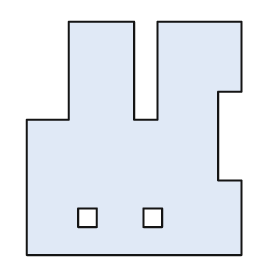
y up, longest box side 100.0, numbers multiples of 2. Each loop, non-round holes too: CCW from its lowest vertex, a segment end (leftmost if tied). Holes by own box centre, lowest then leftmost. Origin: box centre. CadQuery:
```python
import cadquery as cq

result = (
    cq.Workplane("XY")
    .moveTo(-46.0, -50.0)
    .lineTo(46.0, -50.0)
    .lineTo(46.0, -18.0)
    .lineTo(36.0, -18.0)
    .lineTo(36.0, 20.0)
    .lineTo(46.0, 20.0)
    .lineTo(46.0, 50.0)
    .lineTo(10.0, 50.0)
    .lineTo(10.0, 8.0)
    .lineTo(0.0, 8.0)
    .lineTo(0.0, 50.0)
    .lineTo(-28.0, 50.0)
    .lineTo(-28.0, 8.0)
    .lineTo(-46.0, 8.0)
    .close()
    .moveTo(-24.0, -38.0)
    .lineTo(-16.0, -38.0)
    .lineTo(-16.0, -30.0)
    .lineTo(-24.0, -30.0)
    .close()
    .moveTo(4.0, -38.0)
    .lineTo(12.0, -38.0)
    .lineTo(12.0, -30.0)
    .lineTo(4.0, -30.0)
    .close()
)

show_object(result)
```